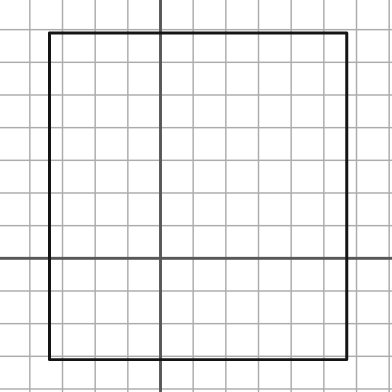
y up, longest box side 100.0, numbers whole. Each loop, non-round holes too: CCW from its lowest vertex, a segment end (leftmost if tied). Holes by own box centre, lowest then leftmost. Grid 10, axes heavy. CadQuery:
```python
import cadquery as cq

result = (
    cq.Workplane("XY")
    .moveTo(-34.0, -31.0)
    .lineTo(57.0, -31.0)
    .lineTo(57.0, 69.0)
    .lineTo(-34.0, 69.0)
    .close()
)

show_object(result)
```